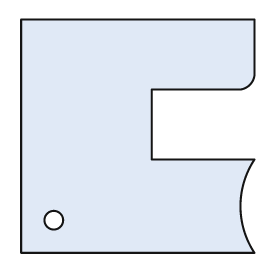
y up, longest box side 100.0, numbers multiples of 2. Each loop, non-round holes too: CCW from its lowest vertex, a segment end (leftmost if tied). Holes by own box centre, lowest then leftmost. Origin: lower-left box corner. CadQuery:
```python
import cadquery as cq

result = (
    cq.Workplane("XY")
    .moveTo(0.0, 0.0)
    .lineTo(100.0, 0.0)
    .threePointArc((94.0, 20.0), (100.0, 40.0))
    .lineTo(56.0, 40.0)
    .lineTo(56.0, 70.0)
    .lineTo(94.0, 70.0)
    .threePointArc((98.0, 72.0), (100.0, 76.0))
    .lineTo(100.0, 100.0)
    .lineTo(0.0, 100.0)
    .close()
    .moveTo(14.0, 14.0)
    .circle(4.0)
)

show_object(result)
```